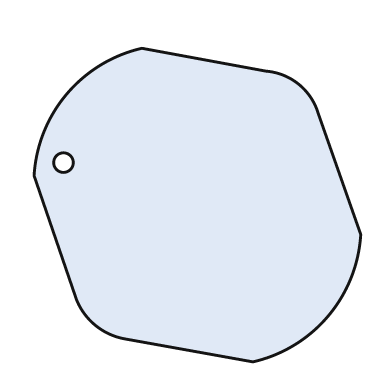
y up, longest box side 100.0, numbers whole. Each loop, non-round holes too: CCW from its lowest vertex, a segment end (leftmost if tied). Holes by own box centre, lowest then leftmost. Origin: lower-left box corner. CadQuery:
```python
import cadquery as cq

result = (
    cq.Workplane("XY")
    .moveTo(67.0, 0.0)
    .threePointArc((90.0, 14.0), (100.0, 39.0))
    .lineTo(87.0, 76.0)
    .threePointArc((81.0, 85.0), (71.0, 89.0))
    .lineTo(33.0, 96.0)
    .threePointArc((10.0, 82.0), (0.0, 57.0))
    .lineTo(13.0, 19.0)
    .threePointArc((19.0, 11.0), (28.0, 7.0))
    .close()
    .moveTo(9.0, 61.0)
    .circle(3.0)
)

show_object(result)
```